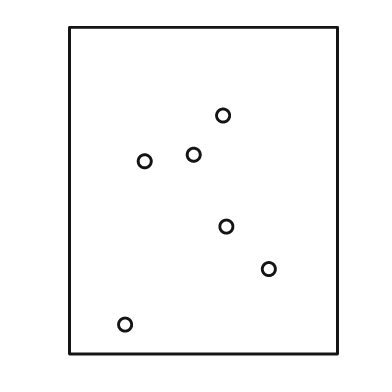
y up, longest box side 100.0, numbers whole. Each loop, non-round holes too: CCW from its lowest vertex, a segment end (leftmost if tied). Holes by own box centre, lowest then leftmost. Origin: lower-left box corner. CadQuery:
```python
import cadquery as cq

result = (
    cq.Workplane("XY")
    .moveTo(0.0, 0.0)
    .lineTo(82.0, 0.0)
    .lineTo(82.0, 100.0)
    .lineTo(0.0, 100.0)
    .close()
    .moveTo(17.0, 9.0)
    .circle(2.0)
    .moveTo(61.0, 26.0)
    .circle(2.0)
    .moveTo(48.0, 39.0)
    .circle(2.0)
    .moveTo(23.0, 59.0)
    .circle(2.0)
    .moveTo(38.0, 61.0)
    .circle(2.0)
    .moveTo(47.0, 73.0)
    .circle(2.0)
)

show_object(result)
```